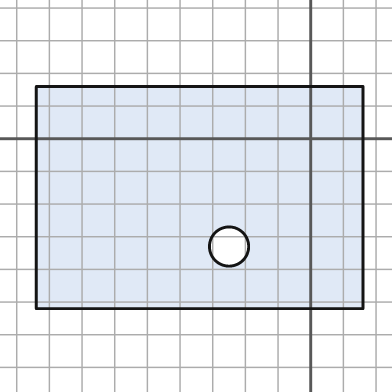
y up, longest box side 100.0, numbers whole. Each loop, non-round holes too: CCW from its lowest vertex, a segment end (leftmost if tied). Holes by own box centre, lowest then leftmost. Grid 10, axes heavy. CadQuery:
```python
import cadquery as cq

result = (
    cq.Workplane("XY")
    .moveTo(-84.0, -52.0)
    .lineTo(16.0, -52.0)
    .lineTo(16.0, 16.0)
    .lineTo(-84.0, 16.0)
    .close()
    .moveTo(-25.0, -33.0)
    .circle(6.0)
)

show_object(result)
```